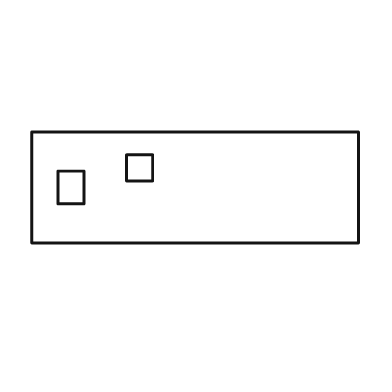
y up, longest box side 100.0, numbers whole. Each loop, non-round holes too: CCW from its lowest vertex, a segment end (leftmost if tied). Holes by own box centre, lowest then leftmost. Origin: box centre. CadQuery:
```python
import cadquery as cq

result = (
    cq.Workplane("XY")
    .moveTo(-50.0, -17.0)
    .lineTo(50.0, -17.0)
    .lineTo(50.0, 17.0)
    .lineTo(-50.0, 17.0)
    .close()
    .moveTo(-42.0, -5.0)
    .lineTo(-34.0, -5.0)
    .lineTo(-34.0, 5.0)
    .lineTo(-42.0, 5.0)
    .close()
    .moveTo(-21.0, 2.0)
    .lineTo(-13.0, 2.0)
    .lineTo(-13.0, 10.0)
    .lineTo(-21.0, 10.0)
    .close()
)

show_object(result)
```